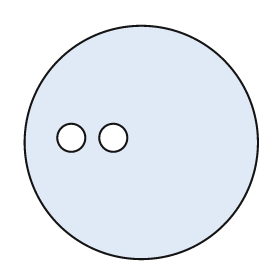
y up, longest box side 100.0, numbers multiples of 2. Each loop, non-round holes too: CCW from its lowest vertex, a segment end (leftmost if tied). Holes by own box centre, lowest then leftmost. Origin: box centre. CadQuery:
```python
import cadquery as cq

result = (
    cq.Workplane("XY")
    .moveTo(0.0, 0.0)
    .circle(50.0)
    .moveTo(-30.0, 2.0)
    .circle(6.0)
    .moveTo(-12.0, 2.0)
    .circle(6.0)
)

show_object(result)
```